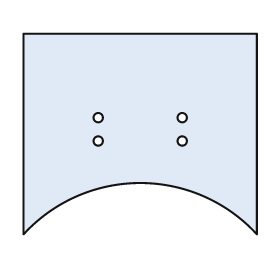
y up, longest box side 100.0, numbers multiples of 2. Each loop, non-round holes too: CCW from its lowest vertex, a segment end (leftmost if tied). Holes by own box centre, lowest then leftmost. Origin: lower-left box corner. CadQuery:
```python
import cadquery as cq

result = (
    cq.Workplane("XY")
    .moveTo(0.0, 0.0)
    .threePointArc((50.0, 22.0), (100.0, 0.0))
    .lineTo(100.0, 86.0)
    .lineTo(0.0, 86.0)
    .close()
    .moveTo(32.0, 40.0)
    .circle(2.0)
    .moveTo(68.0, 40.0)
    .circle(2.0)
    .moveTo(32.0, 50.0)
    .circle(2.0)
    .moveTo(68.0, 50.0)
    .circle(2.0)
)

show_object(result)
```